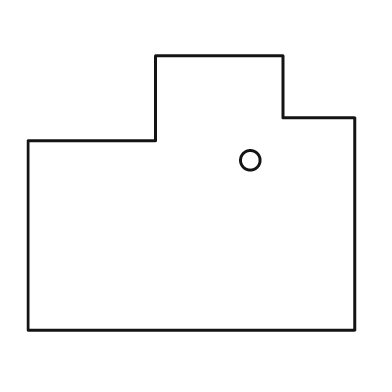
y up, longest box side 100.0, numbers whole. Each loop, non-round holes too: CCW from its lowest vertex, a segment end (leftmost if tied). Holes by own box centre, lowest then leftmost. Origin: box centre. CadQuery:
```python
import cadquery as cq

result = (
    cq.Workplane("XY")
    .moveTo(-50.0, -42.0)
    .lineTo(50.0, -42.0)
    .lineTo(50.0, 23.0)
    .lineTo(28.0, 23.0)
    .lineTo(28.0, 42.0)
    .lineTo(-11.0, 42.0)
    .lineTo(-11.0, 16.0)
    .lineTo(-50.0, 16.0)
    .close()
    .moveTo(18.0, 10.0)
    .circle(3.0)
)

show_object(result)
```